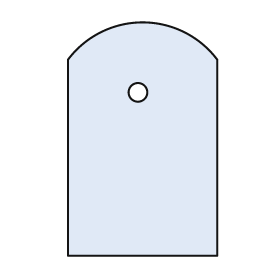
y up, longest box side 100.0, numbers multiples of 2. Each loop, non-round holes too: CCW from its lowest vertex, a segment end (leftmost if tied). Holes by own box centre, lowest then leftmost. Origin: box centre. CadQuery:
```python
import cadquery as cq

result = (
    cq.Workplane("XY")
    .moveTo(-32.0, -50.0)
    .lineTo(32.0, -50.0)
    .lineTo(32.0, 34.0)
    .threePointArc((0.0, 50.0), (-32.0, 34.0))
    .close()
    .moveTo(-2.0, 20.0)
    .circle(4.0)
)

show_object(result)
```